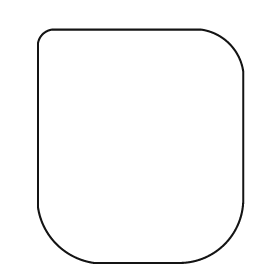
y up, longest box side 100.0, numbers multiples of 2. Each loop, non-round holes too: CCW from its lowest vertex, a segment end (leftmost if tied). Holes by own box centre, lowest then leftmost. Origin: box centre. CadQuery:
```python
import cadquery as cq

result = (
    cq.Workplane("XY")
    .moveTo(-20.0, -50.0)
    .lineTo(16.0, -50.0)
    .threePointArc((36.0, -42.0), (44.0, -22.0))
    .lineTo(44.0, 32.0)
    .threePointArc((38.0, 44.0), (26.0, 50.0))
    .lineTo(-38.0, 50.0)
    .threePointArc((-42.0, 48.0), (-44.0, 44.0))
    .lineTo(-44.0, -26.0)
    .threePointArc((-36.0, -42.0), (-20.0, -50.0))
    .close()
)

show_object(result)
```